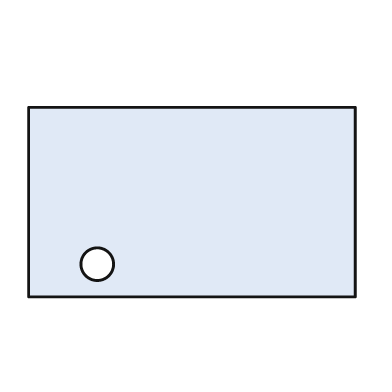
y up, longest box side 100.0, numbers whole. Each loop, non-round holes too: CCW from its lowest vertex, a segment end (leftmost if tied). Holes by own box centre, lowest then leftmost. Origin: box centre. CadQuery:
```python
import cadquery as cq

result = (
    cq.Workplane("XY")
    .moveTo(-50.0, -29.0)
    .lineTo(50.0, -29.0)
    .lineTo(50.0, 29.0)
    .lineTo(-50.0, 29.0)
    .close()
    .moveTo(-29.0, -19.0)
    .circle(5.0)
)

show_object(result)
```